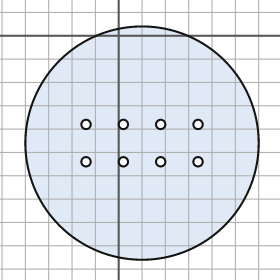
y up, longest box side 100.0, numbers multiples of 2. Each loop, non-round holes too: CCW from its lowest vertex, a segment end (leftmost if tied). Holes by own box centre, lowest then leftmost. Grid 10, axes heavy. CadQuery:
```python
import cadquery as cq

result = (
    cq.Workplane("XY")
    .moveTo(10.0, -46.0)
    .circle(50.0)
    .moveTo(-14.0, -54.0)
    .circle(2.0)
    .moveTo(2.0, -54.0)
    .circle(2.0)
    .moveTo(18.0, -54.0)
    .circle(2.0)
    .moveTo(34.0, -54.0)
    .circle(2.0)
    .moveTo(-14.0, -38.0)
    .circle(2.0)
    .moveTo(2.0, -38.0)
    .circle(2.0)
    .moveTo(18.0, -38.0)
    .circle(2.0)
    .moveTo(34.0, -38.0)
    .circle(2.0)
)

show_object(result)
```